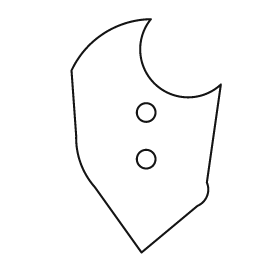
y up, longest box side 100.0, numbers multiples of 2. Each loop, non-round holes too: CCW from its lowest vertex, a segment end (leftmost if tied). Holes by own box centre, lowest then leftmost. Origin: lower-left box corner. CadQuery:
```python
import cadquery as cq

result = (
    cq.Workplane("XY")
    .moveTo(30.0, 0.0)
    .lineTo(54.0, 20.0)
    .threePointArc((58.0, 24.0), (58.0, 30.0))
    .lineTo(64.0, 72.0)
    .threePointArc((36.0, 72.0), (34.0, 100.0))
    .threePointArc((14.0, 94.0), (0.0, 78.0))
    .lineTo(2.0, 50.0)
    .threePointArc((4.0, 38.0), (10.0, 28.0))
    .close()
    .moveTo(32.0, 40.0)
    .circle(4.0)
    .moveTo(32.0, 60.0)
    .circle(4.0)
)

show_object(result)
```